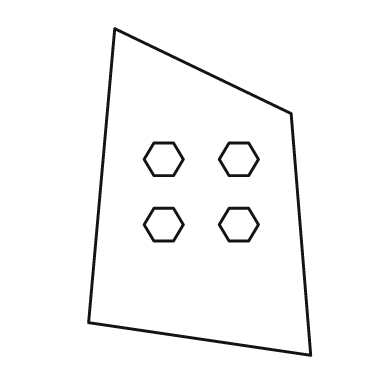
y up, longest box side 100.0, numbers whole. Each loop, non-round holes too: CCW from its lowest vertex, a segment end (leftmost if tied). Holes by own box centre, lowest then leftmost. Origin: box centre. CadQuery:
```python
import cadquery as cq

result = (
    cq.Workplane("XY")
    .moveTo(34.0, -50.0)
    .lineTo(28.0, 24.0)
    .lineTo(-26.0, 50.0)
    .lineTo(-34.0, -40.0)
    .close()
    .moveTo(-14.0, -15.0)
    .lineTo(-8.0, -15.0)
    .lineTo(-5.0, -10.0)
    .lineTo(-8.0, -5.0)
    .lineTo(-14.0, -5.0)
    .lineTo(-17.0, -10.0)
    .close()
    .moveTo(9.0, -15.0)
    .lineTo(15.0, -15.0)
    .lineTo(18.0, -10.0)
    .lineTo(15.0, -5.0)
    .lineTo(9.0, -5.0)
    .lineTo(6.0, -10.0)
    .close()
    .moveTo(-14.0, 5.0)
    .lineTo(-8.0, 5.0)
    .lineTo(-5.0, 10.0)
    .lineTo(-8.0, 15.0)
    .lineTo(-14.0, 15.0)
    .lineTo(-17.0, 10.0)
    .close()
    .moveTo(9.0, 5.0)
    .lineTo(15.0, 5.0)
    .lineTo(18.0, 10.0)
    .lineTo(15.0, 15.0)
    .lineTo(9.0, 15.0)
    .lineTo(6.0, 10.0)
    .close()
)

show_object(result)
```